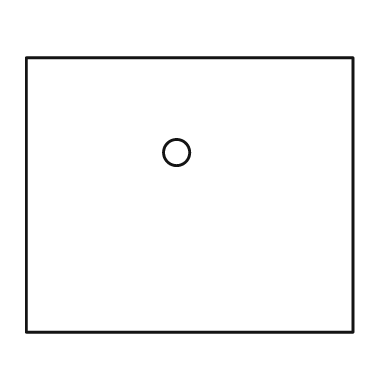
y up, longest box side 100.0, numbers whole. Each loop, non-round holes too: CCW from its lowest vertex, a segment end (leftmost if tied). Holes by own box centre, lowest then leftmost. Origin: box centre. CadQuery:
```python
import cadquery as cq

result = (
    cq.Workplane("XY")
    .moveTo(-50.0, -42.0)
    .lineTo(50.0, -42.0)
    .lineTo(50.0, 42.0)
    .lineTo(-50.0, 42.0)
    .close()
    .moveTo(-4.0, 13.0)
    .circle(4.0)
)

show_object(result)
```